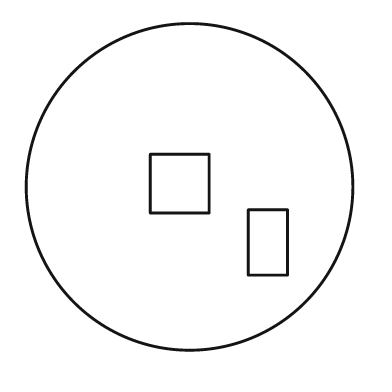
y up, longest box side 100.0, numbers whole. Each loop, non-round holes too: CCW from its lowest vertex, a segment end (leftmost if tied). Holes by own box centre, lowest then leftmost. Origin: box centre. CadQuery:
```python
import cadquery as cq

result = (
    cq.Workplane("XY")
    .moveTo(0.0, 0.0)
    .circle(50.0)
    .moveTo(18.0, -27.0)
    .lineTo(30.0, -27.0)
    .lineTo(30.0, -7.0)
    .lineTo(18.0, -7.0)
    .close()
    .moveTo(-12.0, -8.0)
    .lineTo(6.0, -8.0)
    .lineTo(6.0, 10.0)
    .lineTo(-12.0, 10.0)
    .close()
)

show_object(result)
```